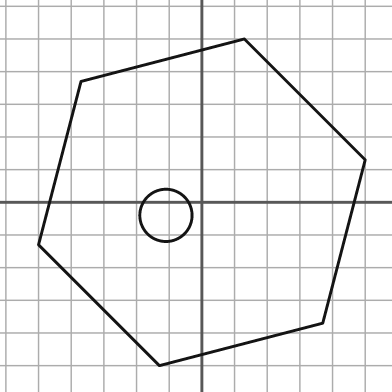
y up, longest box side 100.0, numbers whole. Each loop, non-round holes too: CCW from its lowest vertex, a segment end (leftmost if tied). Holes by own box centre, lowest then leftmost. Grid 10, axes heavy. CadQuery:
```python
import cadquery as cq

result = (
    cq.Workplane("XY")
    .moveTo(-13.0, -50.0)
    .lineTo(37.0, -37.0)
    .lineTo(50.0, 13.0)
    .lineTo(13.0, 50.0)
    .lineTo(-37.0, 37.0)
    .lineTo(-50.0, -13.0)
    .close()
    .moveTo(-11.0, -4.0)
    .circle(8.0)
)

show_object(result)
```